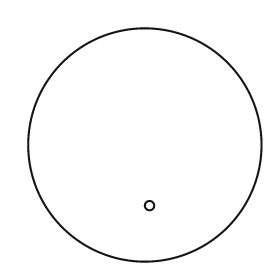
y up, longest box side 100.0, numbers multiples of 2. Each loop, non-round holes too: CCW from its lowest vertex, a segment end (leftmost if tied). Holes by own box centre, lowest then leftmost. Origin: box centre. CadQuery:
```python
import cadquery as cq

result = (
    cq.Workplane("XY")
    .moveTo(0.0, 0.0)
    .circle(50.0)
    .moveTo(2.0, -26.0)
    .circle(2.0)
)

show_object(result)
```